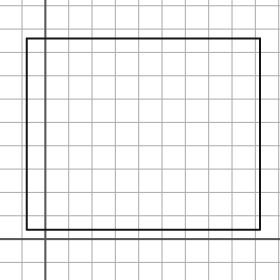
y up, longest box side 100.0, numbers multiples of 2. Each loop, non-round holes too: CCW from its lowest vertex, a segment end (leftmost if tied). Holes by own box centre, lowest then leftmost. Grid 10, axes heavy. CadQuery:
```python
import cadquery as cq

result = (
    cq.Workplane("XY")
    .moveTo(-8.0, 4.0)
    .lineTo(92.0, 4.0)
    .lineTo(92.0, 86.0)
    .lineTo(-8.0, 86.0)
    .close()
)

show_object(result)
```